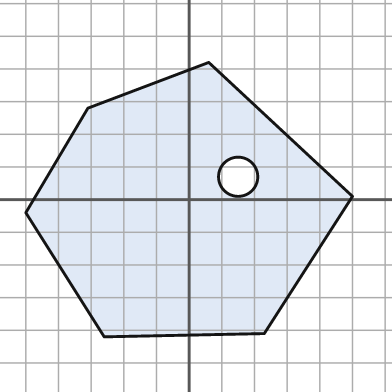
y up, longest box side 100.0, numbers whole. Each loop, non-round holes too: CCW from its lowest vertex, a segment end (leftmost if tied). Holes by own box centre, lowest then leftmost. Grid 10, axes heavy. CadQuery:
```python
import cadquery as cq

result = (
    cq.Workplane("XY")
    .moveTo(-26.0, -42.0)
    .lineTo(23.0, -41.0)
    .lineTo(50.0, 1.0)
    .lineTo(6.0, 42.0)
    .lineTo(-31.0, 28.0)
    .lineTo(-50.0, -4.0)
    .close()
    .moveTo(15.0, 7.0)
    .circle(6.0)
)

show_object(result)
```